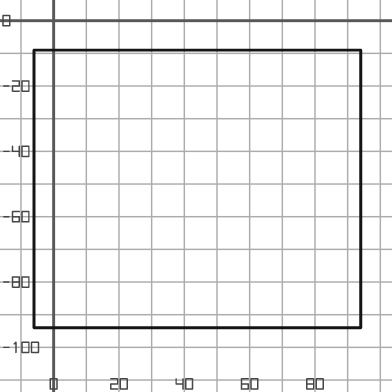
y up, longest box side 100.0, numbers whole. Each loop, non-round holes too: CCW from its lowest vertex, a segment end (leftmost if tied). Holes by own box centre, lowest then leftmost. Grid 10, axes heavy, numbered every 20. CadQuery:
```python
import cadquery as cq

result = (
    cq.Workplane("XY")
    .moveTo(-6.0, -94.0)
    .lineTo(94.0, -94.0)
    .lineTo(94.0, -9.0)
    .lineTo(-6.0, -9.0)
    .close()
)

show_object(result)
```